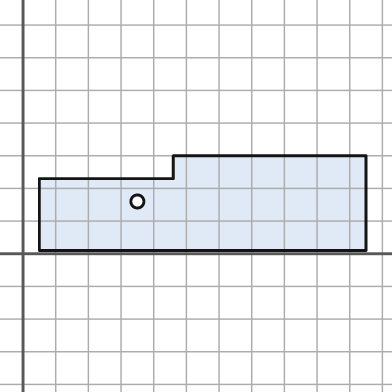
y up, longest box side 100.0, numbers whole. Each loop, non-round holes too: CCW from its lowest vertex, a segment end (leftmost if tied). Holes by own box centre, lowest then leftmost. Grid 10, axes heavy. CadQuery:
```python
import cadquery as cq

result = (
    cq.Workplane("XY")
    .moveTo(5.0, 1.0)
    .lineTo(105.0, 1.0)
    .lineTo(105.0, 30.0)
    .lineTo(46.0, 30.0)
    .lineTo(46.0, 23.0)
    .lineTo(5.0, 23.0)
    .close()
    .moveTo(35.0, 16.0)
    .circle(2.0)
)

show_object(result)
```